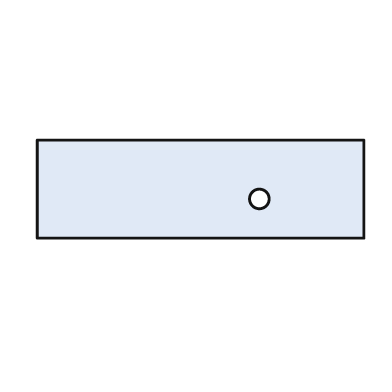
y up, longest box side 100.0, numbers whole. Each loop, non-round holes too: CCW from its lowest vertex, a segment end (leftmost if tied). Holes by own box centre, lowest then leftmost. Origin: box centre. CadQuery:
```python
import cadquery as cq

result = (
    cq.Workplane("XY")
    .moveTo(-50.0, -15.0)
    .lineTo(50.0, -15.0)
    .lineTo(50.0, 15.0)
    .lineTo(-50.0, 15.0)
    .close()
    .moveTo(18.0, -3.0)
    .circle(3.0)
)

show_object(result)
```